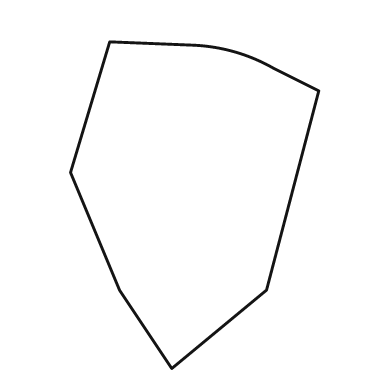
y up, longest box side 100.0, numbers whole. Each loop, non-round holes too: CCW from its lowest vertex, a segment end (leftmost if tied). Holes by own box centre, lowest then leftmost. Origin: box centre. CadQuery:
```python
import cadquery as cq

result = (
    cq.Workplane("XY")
    .moveTo(-7.0, -50.0)
    .lineTo(22.0, -26.0)
    .lineTo(38.0, 35.0)
    .lineTo(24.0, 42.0)
    .threePointArc((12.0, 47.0), (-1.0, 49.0))
    .lineTo(-26.0, 50.0)
    .lineTo(-38.0, 10.0)
    .lineTo(-23.0, -26.0)
    .close()
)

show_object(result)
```